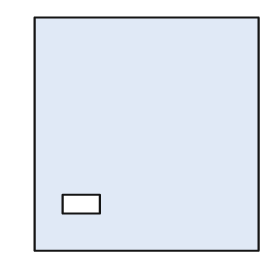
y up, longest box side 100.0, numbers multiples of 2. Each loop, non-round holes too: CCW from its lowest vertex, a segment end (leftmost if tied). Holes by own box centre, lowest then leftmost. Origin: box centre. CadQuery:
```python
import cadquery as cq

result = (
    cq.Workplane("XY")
    .moveTo(-48.0, -50.0)
    .lineTo(48.0, -50.0)
    .lineTo(48.0, 50.0)
    .lineTo(-48.0, 50.0)
    .close()
    .moveTo(-36.0, -34.0)
    .lineTo(-20.0, -34.0)
    .lineTo(-20.0, -26.0)
    .lineTo(-36.0, -26.0)
    .close()
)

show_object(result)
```